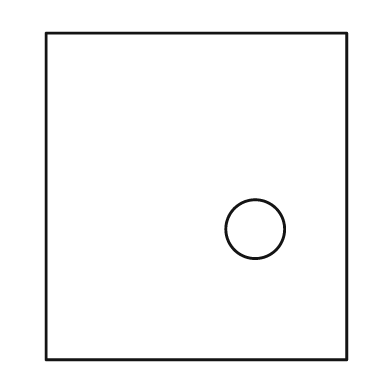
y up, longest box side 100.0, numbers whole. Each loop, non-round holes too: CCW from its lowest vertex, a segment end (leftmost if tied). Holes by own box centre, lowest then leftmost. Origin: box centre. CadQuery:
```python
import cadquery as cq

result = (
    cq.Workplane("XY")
    .moveTo(-46.0, -50.0)
    .lineTo(46.0, -50.0)
    .lineTo(46.0, 50.0)
    .lineTo(-46.0, 50.0)
    .close()
    .moveTo(18.0, -10.0)
    .circle(9.0)
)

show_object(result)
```